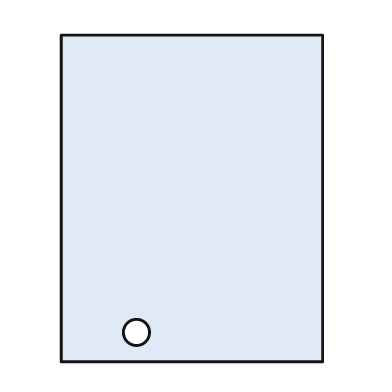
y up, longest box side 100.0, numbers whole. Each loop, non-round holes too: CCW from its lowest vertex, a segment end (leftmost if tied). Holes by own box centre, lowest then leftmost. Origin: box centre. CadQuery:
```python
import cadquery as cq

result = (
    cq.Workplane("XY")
    .moveTo(-40.0, -50.0)
    .lineTo(40.0, -50.0)
    .lineTo(40.0, 50.0)
    .lineTo(-40.0, 50.0)
    .close()
    .moveTo(-17.0, -41.0)
    .circle(4.0)
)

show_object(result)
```